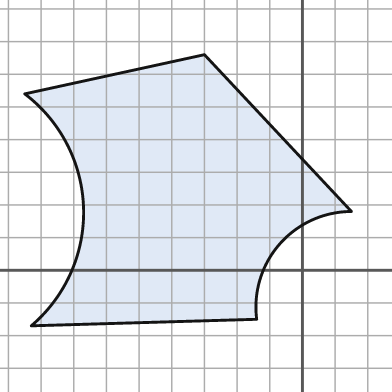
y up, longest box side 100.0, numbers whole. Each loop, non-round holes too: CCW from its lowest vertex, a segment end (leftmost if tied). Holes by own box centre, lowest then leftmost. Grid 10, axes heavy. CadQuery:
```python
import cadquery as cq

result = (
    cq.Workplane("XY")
    .moveTo(-83.0, -17.0)
    .lineTo(-14.0, -15.0)
    .threePointArc((-7.0, 8.0), (15.0, 18.0))
    .lineTo(-30.0, 66.0)
    .lineTo(-85.0, 54.0)
    .threePointArc((-67.0, 19.0), (-83.0, -17.0))
    .close()
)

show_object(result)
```